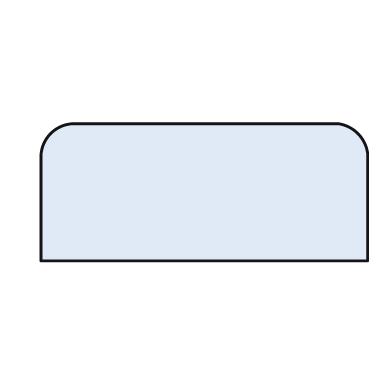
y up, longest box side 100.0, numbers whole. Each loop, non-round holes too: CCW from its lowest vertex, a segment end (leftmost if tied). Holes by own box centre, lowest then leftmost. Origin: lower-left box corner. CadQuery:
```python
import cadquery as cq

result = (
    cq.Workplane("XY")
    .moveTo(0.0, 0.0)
    .lineTo(100.0, 0.0)
    .lineTo(100.0, 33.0)
    .threePointArc((97.0, 39.0), (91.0, 42.0))
    .lineTo(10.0, 42.0)
    .threePointArc((3.0, 39.0), (0.0, 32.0))
    .close()
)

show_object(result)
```